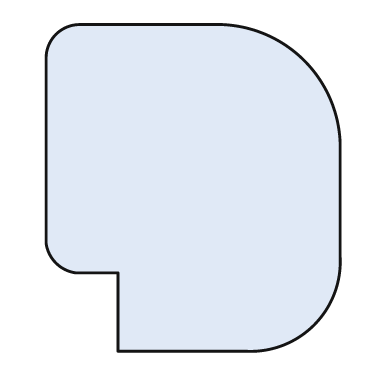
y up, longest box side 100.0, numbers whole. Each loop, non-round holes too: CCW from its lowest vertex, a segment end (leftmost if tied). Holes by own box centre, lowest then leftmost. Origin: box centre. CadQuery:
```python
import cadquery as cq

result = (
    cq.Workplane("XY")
    .moveTo(-23.0, -50.0)
    .lineTo(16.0, -50.0)
    .threePointArc((37.0, -42.0), (45.0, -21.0))
    .lineTo(45.0, 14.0)
    .threePointArc((34.0, 39.0), (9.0, 50.0))
    .lineTo(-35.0, 50.0)
    .threePointArc((-42.0, 47.0), (-45.0, 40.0))
    .lineTo(-45.0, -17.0)
    .threePointArc((-42.0, -23.0), (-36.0, -26.0))
    .lineTo(-23.0, -26.0)
    .close()
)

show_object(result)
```